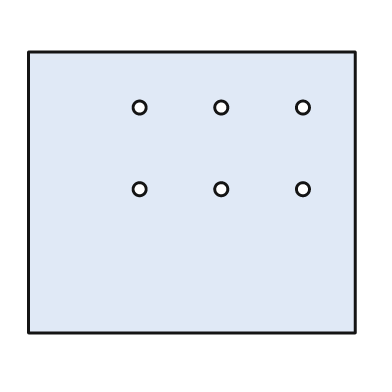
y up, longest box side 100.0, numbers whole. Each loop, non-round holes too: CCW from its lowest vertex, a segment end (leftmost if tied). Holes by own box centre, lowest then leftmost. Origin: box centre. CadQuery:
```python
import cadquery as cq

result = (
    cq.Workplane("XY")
    .moveTo(-50.0, -43.0)
    .lineTo(50.0, -43.0)
    .lineTo(50.0, 43.0)
    .lineTo(-50.0, 43.0)
    .close()
    .moveTo(-16.0, 1.0)
    .circle(2.0)
    .moveTo(9.0, 1.0)
    .circle(2.0)
    .moveTo(34.0, 1.0)
    .circle(2.0)
    .moveTo(-16.0, 26.0)
    .circle(2.0)
    .moveTo(9.0, 26.0)
    .circle(2.0)
    .moveTo(34.0, 26.0)
    .circle(2.0)
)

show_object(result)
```